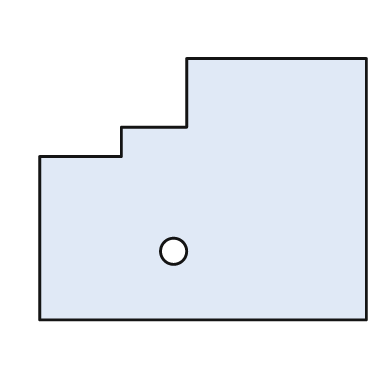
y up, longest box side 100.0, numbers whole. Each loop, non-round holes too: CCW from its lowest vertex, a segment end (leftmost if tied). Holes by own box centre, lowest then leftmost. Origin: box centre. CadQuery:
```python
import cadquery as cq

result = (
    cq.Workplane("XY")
    .moveTo(-50.0, -40.0)
    .lineTo(50.0, -40.0)
    .lineTo(50.0, 40.0)
    .lineTo(-5.0, 40.0)
    .lineTo(-5.0, 19.0)
    .lineTo(-25.0, 19.0)
    .lineTo(-25.0, 10.0)
    .lineTo(-50.0, 10.0)
    .close()
    .moveTo(-9.0, -19.0)
    .circle(4.0)
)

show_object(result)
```